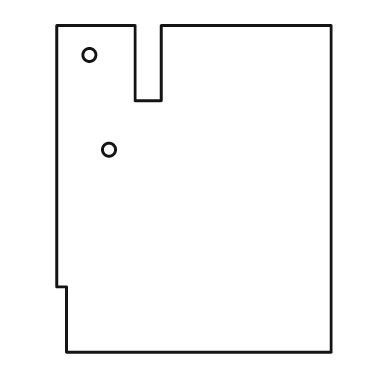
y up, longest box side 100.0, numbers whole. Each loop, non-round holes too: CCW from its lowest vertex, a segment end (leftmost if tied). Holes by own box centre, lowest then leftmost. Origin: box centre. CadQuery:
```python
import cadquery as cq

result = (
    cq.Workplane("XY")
    .moveTo(-39.0, -50.0)
    .lineTo(42.0, -50.0)
    .lineTo(42.0, 50.0)
    .lineTo(-10.0, 50.0)
    .lineTo(-10.0, 27.0)
    .lineTo(-18.0, 27.0)
    .lineTo(-18.0, 50.0)
    .lineTo(-42.0, 50.0)
    .lineTo(-42.0, -30.0)
    .lineTo(-39.0, -30.0)
    .close()
    .moveTo(-26.0, 12.0)
    .circle(2.0)
    .moveTo(-32.0, 41.0)
    .circle(2.0)
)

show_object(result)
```